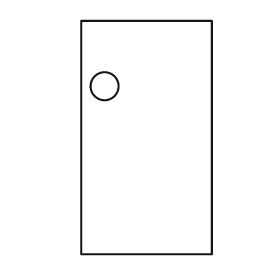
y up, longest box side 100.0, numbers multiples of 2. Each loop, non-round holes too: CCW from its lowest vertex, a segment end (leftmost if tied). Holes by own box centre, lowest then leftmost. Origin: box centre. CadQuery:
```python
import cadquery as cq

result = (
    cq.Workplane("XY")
    .moveTo(-28.0, -50.0)
    .lineTo(28.0, -50.0)
    .lineTo(28.0, 50.0)
    .lineTo(-28.0, 50.0)
    .close()
    .moveTo(-18.0, 22.0)
    .circle(6.0)
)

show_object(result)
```